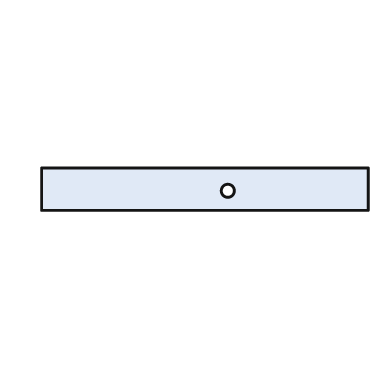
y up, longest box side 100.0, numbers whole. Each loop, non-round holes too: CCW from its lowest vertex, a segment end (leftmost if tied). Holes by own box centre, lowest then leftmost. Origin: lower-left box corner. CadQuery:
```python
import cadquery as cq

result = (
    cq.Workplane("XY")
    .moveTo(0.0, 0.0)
    .lineTo(100.0, 0.0)
    .lineTo(100.0, 13.0)
    .lineTo(0.0, 13.0)
    .close()
    .moveTo(57.0, 6.0)
    .circle(2.0)
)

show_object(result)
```